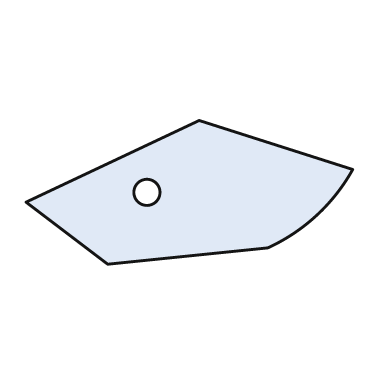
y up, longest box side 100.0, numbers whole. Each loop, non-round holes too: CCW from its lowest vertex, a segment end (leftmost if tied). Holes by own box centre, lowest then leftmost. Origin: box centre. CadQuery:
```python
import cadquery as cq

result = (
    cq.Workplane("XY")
    .moveTo(-25.0, -22.0)
    .lineTo(24.0, -17.0)
    .threePointArc((39.0, -7.0), (50.0, 7.0))
    .lineTo(3.0, 22.0)
    .lineTo(-50.0, -3.0)
    .close()
    .moveTo(-13.0, 0.0)
    .circle(4.0)
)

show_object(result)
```